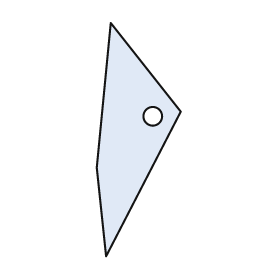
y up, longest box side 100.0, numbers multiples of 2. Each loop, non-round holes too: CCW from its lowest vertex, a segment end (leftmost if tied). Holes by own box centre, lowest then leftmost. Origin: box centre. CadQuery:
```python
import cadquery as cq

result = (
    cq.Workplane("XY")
    .moveTo(-14.0, -50.0)
    .lineTo(18.0, 12.0)
    .lineTo(-12.0, 50.0)
    .lineTo(-18.0, -12.0)
    .close()
    .moveTo(6.0, 10.0)
    .circle(4.0)
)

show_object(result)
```